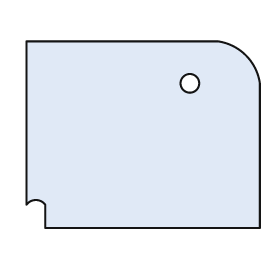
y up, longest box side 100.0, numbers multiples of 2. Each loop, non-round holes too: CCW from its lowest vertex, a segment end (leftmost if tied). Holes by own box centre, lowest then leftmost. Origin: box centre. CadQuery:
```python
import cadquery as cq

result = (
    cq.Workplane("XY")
    .moveTo(-42.0, -40.0)
    .lineTo(50.0, -40.0)
    .lineTo(50.0, 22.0)
    .threePointArc((44.0, 34.0), (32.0, 40.0))
    .lineTo(-50.0, 40.0)
    .lineTo(-50.0, -30.0)
    .threePointArc((-46.0, -28.0), (-42.0, -30.0))
    .close()
    .moveTo(20.0, 22.0)
    .circle(4.0)
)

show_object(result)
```